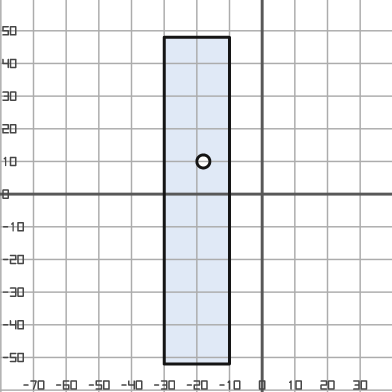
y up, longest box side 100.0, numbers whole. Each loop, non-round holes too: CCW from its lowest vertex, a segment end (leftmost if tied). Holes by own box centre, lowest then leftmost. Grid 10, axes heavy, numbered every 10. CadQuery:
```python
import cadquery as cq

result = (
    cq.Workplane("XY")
    .moveTo(-30.0, -52.0)
    .lineTo(-10.0, -52.0)
    .lineTo(-10.0, 48.0)
    .lineTo(-30.0, 48.0)
    .close()
    .moveTo(-18.0, 10.0)
    .circle(2.0)
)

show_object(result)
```